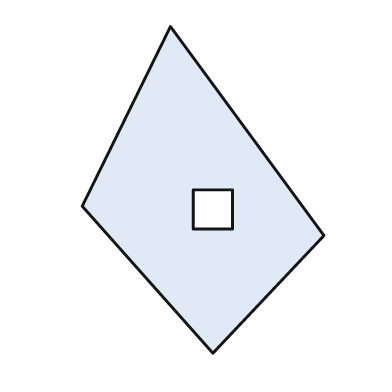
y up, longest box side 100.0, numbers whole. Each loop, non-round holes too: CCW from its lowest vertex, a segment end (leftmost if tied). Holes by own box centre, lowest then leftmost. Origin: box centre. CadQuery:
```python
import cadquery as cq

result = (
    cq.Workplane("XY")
    .moveTo(3.0, -50.0)
    .lineTo(37.0, -14.0)
    .lineTo(-10.0, 50.0)
    .lineTo(-37.0, -5.0)
    .close()
    .moveTo(-3.0, -12.0)
    .lineTo(9.0, -12.0)
    .lineTo(9.0, 0.0)
    .lineTo(-3.0, 0.0)
    .close()
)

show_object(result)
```